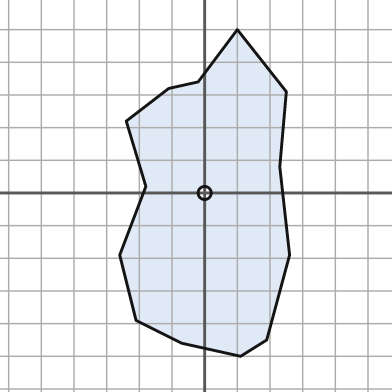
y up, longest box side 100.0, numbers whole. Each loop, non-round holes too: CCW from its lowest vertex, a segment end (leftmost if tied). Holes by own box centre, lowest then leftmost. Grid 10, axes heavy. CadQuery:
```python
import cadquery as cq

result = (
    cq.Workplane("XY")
    .moveTo(11.0, -50.0)
    .lineTo(19.0, -45.0)
    .lineTo(26.0, -19.0)
    .lineTo(23.0, 8.0)
    .lineTo(25.0, 31.0)
    .lineTo(10.0, 50.0)
    .lineTo(-2.0, 34.0)
    .lineTo(-11.0, 32.0)
    .lineTo(-24.0, 22.0)
    .lineTo(-18.0, 2.0)
    .lineTo(-26.0, -19.0)
    .lineTo(-21.0, -39.0)
    .lineTo(-7.0, -46.0)
    .close()
    .moveTo(0.0, 0.0)
    .circle(2.0)
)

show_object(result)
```